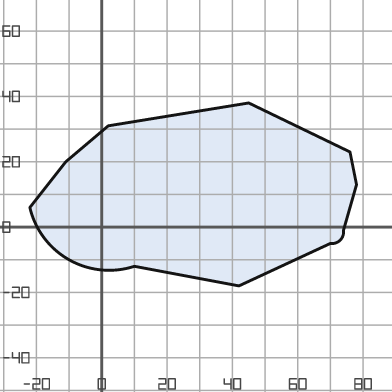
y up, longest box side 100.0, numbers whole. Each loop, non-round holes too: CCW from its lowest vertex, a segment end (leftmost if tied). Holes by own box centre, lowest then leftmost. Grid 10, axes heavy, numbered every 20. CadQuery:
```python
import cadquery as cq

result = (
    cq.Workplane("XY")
    .moveTo(42.0, -18.0)
    .lineTo(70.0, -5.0)
    .threePointArc((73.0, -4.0), (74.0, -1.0))
    .lineTo(78.0, 13.0)
    .lineTo(76.0, 23.0)
    .lineTo(45.0, 38.0)
    .lineTo(2.0, 31.0)
    .lineTo(-11.0, 20.0)
    .lineTo(-22.0, 6.0)
    .threePointArc((-10.0, -10.0), (10.0, -12.0))
    .close()
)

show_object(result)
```